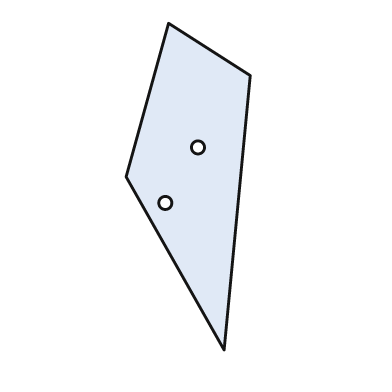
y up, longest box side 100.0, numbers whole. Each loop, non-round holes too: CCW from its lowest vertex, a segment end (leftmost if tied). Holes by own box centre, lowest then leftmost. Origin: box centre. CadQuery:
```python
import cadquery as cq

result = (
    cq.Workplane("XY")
    .moveTo(11.0, -50.0)
    .lineTo(19.0, 34.0)
    .lineTo(-6.0, 50.0)
    .lineTo(-19.0, 3.0)
    .close()
    .moveTo(-7.0, -5.0)
    .circle(2.0)
    .moveTo(3.0, 12.0)
    .circle(2.0)
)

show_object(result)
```